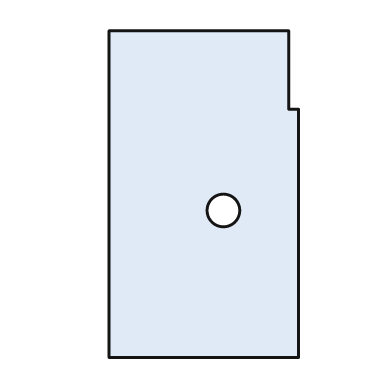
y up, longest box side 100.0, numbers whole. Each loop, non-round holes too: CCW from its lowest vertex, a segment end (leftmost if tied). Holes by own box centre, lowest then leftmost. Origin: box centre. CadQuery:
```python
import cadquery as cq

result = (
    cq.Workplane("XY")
    .moveTo(-29.0, -50.0)
    .lineTo(29.0, -50.0)
    .lineTo(29.0, 26.0)
    .lineTo(26.0, 26.0)
    .lineTo(26.0, 50.0)
    .lineTo(-29.0, 50.0)
    .close()
    .moveTo(6.0, -5.0)
    .circle(5.0)
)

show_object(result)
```